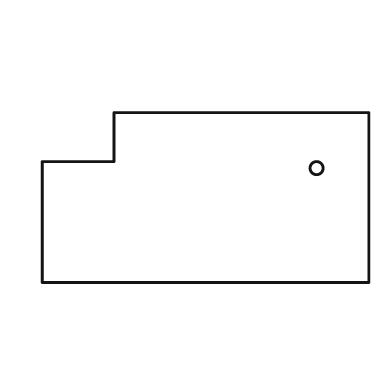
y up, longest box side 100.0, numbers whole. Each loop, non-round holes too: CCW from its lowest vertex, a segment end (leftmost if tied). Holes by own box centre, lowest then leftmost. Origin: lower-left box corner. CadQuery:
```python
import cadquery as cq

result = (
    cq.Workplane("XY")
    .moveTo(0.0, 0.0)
    .lineTo(100.0, 0.0)
    .lineTo(100.0, 52.0)
    .lineTo(22.0, 52.0)
    .lineTo(22.0, 37.0)
    .lineTo(0.0, 37.0)
    .close()
    .moveTo(84.0, 35.0)
    .circle(2.0)
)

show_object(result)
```